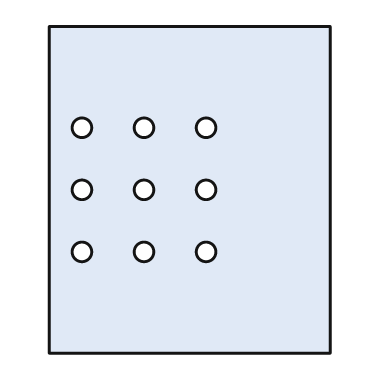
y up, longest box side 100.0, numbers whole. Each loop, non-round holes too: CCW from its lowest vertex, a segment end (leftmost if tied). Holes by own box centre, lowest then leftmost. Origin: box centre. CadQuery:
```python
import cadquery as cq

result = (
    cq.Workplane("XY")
    .moveTo(-43.0, -50.0)
    .lineTo(43.0, -50.0)
    .lineTo(43.0, 50.0)
    .lineTo(-43.0, 50.0)
    .close()
    .moveTo(-33.0, -19.0)
    .circle(3.0)
    .moveTo(-14.0, -19.0)
    .circle(3.0)
    .moveTo(5.0, -19.0)
    .circle(3.0)
    .moveTo(-33.0, 0.0)
    .circle(3.0)
    .moveTo(-14.0, 0.0)
    .circle(3.0)
    .moveTo(5.0, 0.0)
    .circle(3.0)
    .moveTo(-33.0, 19.0)
    .circle(3.0)
    .moveTo(-14.0, 19.0)
    .circle(3.0)
    .moveTo(5.0, 19.0)
    .circle(3.0)
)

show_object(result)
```